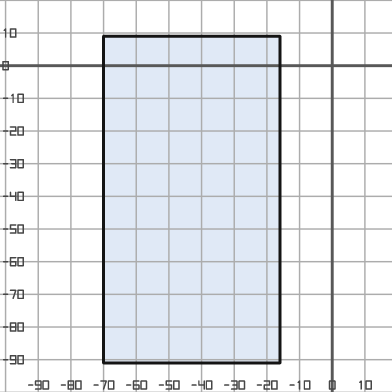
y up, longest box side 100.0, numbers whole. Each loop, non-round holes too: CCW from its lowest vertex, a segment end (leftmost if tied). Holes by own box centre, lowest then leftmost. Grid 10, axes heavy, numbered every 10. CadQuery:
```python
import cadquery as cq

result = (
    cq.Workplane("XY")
    .moveTo(-70.0, -91.0)
    .lineTo(-16.0, -91.0)
    .lineTo(-16.0, 9.0)
    .lineTo(-70.0, 9.0)
    .close()
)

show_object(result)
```